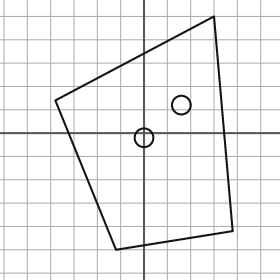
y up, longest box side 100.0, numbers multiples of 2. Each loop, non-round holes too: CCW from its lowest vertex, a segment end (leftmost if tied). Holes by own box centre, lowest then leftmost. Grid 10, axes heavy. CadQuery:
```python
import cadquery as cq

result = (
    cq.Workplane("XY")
    .moveTo(-12.0, -50.0)
    .lineTo(38.0, -42.0)
    .lineTo(30.0, 50.0)
    .lineTo(-38.0, 14.0)
    .close()
    .moveTo(0.0, -2.0)
    .circle(4.0)
    .moveTo(16.0, 12.0)
    .circle(4.0)
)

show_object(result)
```